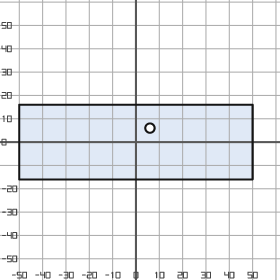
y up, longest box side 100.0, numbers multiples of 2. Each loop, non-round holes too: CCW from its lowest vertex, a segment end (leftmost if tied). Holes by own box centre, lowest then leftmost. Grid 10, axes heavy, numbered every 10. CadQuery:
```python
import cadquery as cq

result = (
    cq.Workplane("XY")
    .moveTo(-50.0, -16.0)
    .lineTo(50.0, -16.0)
    .lineTo(50.0, 16.0)
    .lineTo(-50.0, 16.0)
    .close()
    .moveTo(6.0, 6.0)
    .circle(2.0)
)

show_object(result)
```